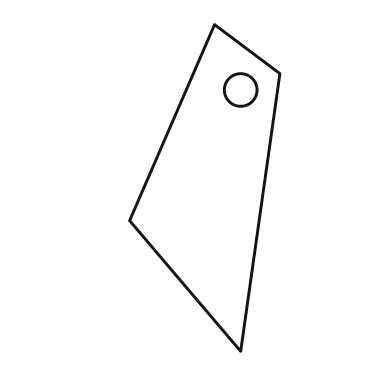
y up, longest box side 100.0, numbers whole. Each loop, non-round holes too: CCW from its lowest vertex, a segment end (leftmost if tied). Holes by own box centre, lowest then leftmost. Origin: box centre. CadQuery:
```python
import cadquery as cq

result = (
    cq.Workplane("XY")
    .moveTo(11.0, -50.0)
    .lineTo(23.0, 35.0)
    .lineTo(3.0, 50.0)
    .lineTo(-23.0, -10.0)
    .close()
    .moveTo(11.0, 30.0)
    .circle(5.0)
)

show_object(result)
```